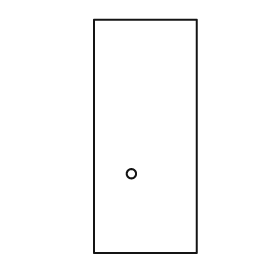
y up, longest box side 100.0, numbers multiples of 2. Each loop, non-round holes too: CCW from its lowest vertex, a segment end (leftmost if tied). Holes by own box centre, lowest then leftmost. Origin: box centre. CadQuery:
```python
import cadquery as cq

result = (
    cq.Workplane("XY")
    .moveTo(-22.0, -50.0)
    .lineTo(22.0, -50.0)
    .lineTo(22.0, 50.0)
    .lineTo(-22.0, 50.0)
    .close()
    .moveTo(-6.0, -16.0)
    .circle(2.0)
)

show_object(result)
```